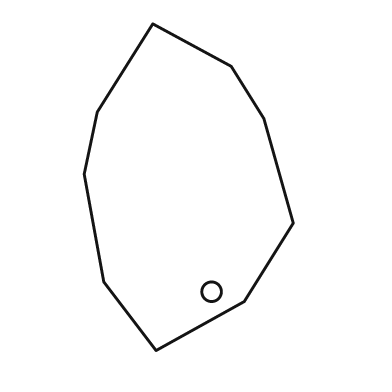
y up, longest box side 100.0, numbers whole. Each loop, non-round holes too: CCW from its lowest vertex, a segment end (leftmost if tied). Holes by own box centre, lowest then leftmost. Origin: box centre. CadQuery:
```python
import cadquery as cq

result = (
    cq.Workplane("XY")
    .moveTo(-10.0, -50.0)
    .lineTo(17.0, -35.0)
    .lineTo(32.0, -11.0)
    .lineTo(23.0, 21.0)
    .lineTo(13.0, 37.0)
    .lineTo(-11.0, 50.0)
    .lineTo(-28.0, 23.0)
    .lineTo(-32.0, 4.0)
    .lineTo(-26.0, -29.0)
    .close()
    .moveTo(7.0, -32.0)
    .circle(3.0)
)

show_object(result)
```